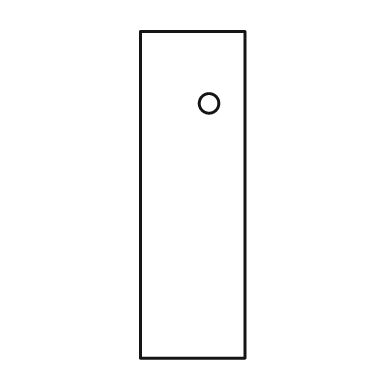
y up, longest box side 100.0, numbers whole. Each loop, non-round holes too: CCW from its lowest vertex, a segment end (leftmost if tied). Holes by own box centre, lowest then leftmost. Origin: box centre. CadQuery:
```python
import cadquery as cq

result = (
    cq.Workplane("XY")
    .moveTo(-16.0, -50.0)
    .lineTo(16.0, -50.0)
    .lineTo(16.0, 50.0)
    .lineTo(-16.0, 50.0)
    .close()
    .moveTo(5.0, 28.0)
    .circle(3.0)
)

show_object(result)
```